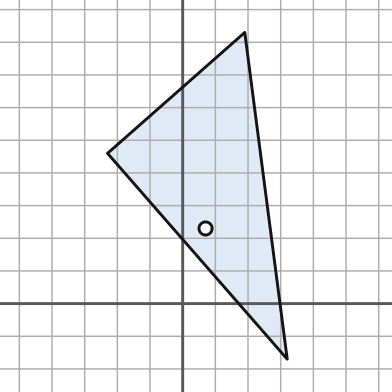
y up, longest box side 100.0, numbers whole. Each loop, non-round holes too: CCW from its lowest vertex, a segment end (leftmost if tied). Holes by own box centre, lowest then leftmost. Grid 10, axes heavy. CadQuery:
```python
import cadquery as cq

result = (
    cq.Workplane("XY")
    .moveTo(32.0, -17.0)
    .lineTo(19.0, 83.0)
    .lineTo(-23.0, 46.0)
    .close()
    .moveTo(7.0, 23.0)
    .circle(2.0)
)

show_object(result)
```